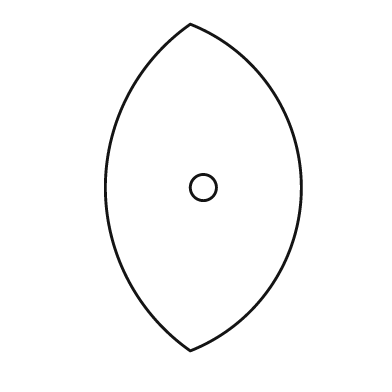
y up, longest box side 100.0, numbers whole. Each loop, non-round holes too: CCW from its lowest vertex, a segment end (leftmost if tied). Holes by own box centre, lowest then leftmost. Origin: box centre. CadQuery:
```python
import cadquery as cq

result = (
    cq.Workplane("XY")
    .moveTo(-4.0, -50.0)
    .threePointArc((30.0, 0.0), (-4.0, 50.0))
    .threePointArc((-30.0, 0.0), (-4.0, -50.0))
    .close()
    .moveTo(0.0, 0.0)
    .circle(4.0)
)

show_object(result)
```